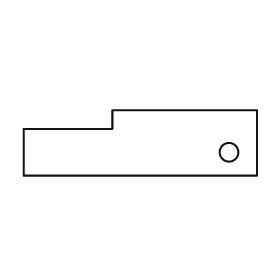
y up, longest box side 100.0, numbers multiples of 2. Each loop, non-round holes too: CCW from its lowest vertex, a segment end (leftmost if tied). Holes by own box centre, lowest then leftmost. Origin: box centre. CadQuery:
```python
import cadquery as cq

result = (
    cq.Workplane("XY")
    .moveTo(-50.0, -14.0)
    .lineTo(50.0, -14.0)
    .lineTo(50.0, 14.0)
    .lineTo(-12.0, 14.0)
    .lineTo(-12.0, 6.0)
    .lineTo(-50.0, 6.0)
    .close()
    .moveTo(38.0, -4.0)
    .circle(4.0)
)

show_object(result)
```